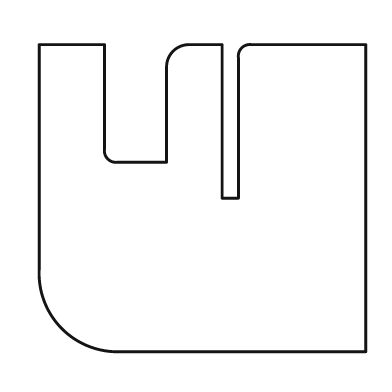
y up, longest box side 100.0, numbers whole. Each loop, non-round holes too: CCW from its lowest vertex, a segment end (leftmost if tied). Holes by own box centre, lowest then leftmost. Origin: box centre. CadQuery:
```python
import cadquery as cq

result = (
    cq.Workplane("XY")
    .moveTo(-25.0, -47.0)
    .lineTo(50.0, -47.0)
    .lineTo(50.0, 47.0)
    .lineTo(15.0, 47.0)
    .threePointArc((12.0, 46.0), (11.0, 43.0))
    .lineTo(11.0, 0.0)
    .lineTo(6.0, 0.0)
    .lineTo(6.0, 47.0)
    .lineTo(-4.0, 47.0)
    .threePointArc((-9.0, 45.0), (-11.0, 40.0))
    .lineTo(-11.0, 11.0)
    .lineTo(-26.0, 11.0)
    .threePointArc((-29.0, 12.0), (-30.0, 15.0))
    .lineTo(-30.0, 47.0)
    .lineTo(-50.0, 47.0)
    .lineTo(-50.0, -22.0)
    .threePointArc((-43.0, -40.0), (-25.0, -47.0))
    .close()
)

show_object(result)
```